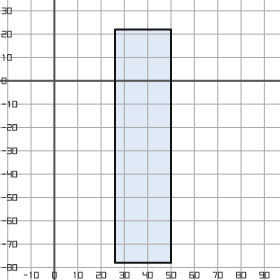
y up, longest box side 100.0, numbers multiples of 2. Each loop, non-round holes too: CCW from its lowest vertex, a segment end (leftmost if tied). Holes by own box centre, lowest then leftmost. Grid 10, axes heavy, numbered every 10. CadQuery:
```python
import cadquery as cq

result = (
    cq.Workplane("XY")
    .moveTo(26.0, -78.0)
    .lineTo(50.0, -78.0)
    .lineTo(50.0, 22.0)
    .lineTo(26.0, 22.0)
    .close()
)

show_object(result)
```